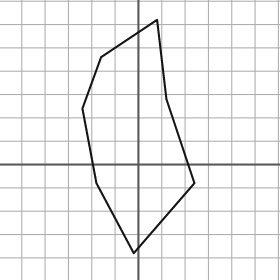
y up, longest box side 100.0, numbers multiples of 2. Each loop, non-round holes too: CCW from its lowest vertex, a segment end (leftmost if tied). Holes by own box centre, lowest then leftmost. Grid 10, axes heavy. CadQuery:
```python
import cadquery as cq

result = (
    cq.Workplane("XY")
    .moveTo(-2.0, -38.0)
    .lineTo(24.0, -8.0)
    .lineTo(12.0, 28.0)
    .lineTo(8.0, 62.0)
    .lineTo(-16.0, 46.0)
    .lineTo(-24.0, 24.0)
    .lineTo(-18.0, -8.0)
    .close()
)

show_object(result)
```